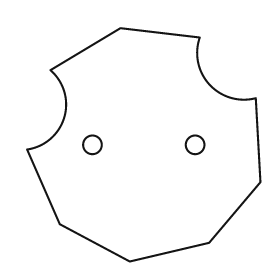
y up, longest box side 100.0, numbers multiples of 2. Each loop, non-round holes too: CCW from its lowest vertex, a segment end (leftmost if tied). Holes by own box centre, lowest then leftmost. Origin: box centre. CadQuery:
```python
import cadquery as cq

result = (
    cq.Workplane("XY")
    .moveTo(-6.0, -50.0)
    .lineTo(28.0, -42.0)
    .lineTo(50.0, -16.0)
    .lineTo(48.0, 20.0)
    .threePointArc((28.0, 26.0), (24.0, 46.0))
    .lineTo(-10.0, 50.0)
    .lineTo(-40.0, 32.0)
    .threePointArc((-34.0, 12.0), (-50.0, -2.0))
    .lineTo(-36.0, -34.0)
    .close()
    .moveTo(-22.0, 0.0)
    .circle(4.0)
    .moveTo(22.0, 0.0)
    .circle(4.0)
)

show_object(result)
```